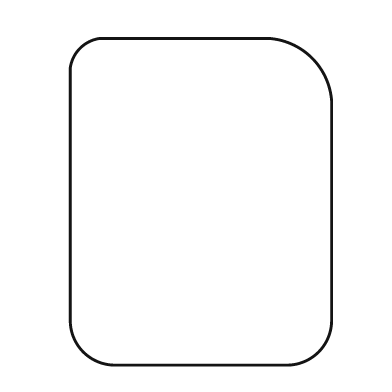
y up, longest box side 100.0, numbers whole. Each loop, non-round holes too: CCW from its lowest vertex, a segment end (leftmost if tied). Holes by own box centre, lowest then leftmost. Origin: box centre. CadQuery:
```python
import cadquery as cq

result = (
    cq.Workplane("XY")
    .moveTo(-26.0, -50.0)
    .lineTo(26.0, -50.0)
    .threePointArc((36.0, -46.0), (40.0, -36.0))
    .lineTo(40.0, 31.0)
    .threePointArc((34.0, 44.0), (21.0, 50.0))
    .lineTo(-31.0, 50.0)
    .threePointArc((-37.0, 47.0), (-40.0, 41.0))
    .lineTo(-40.0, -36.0)
    .threePointArc((-36.0, -46.0), (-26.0, -50.0))
    .close()
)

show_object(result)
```